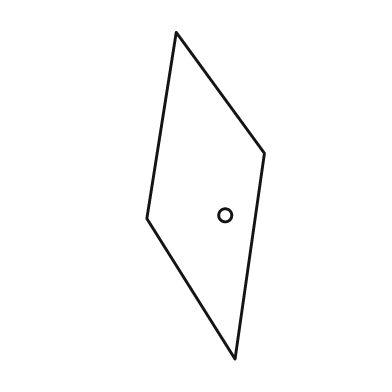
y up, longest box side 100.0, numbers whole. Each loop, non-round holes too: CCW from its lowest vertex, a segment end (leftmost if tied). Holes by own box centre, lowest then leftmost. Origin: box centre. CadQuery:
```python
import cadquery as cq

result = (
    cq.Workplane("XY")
    .moveTo(9.0, -50.0)
    .lineTo(18.0, 13.0)
    .lineTo(-9.0, 50.0)
    .lineTo(-18.0, -7.0)
    .close()
    .moveTo(6.0, -6.0)
    .circle(2.0)
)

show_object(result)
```